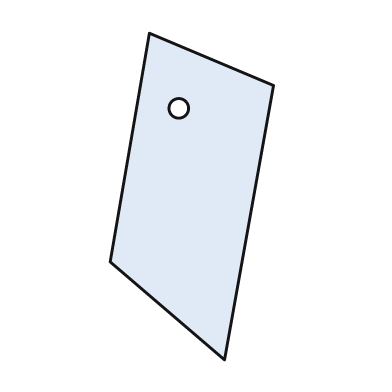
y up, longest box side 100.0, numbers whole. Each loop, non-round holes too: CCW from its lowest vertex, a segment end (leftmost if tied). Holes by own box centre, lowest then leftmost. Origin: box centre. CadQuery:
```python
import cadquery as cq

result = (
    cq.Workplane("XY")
    .moveTo(10.0, -50.0)
    .lineTo(25.0, 34.0)
    .lineTo(-13.0, 50.0)
    .lineTo(-25.0, -20.0)
    .close()
    .moveTo(-4.0, 27.0)
    .circle(3.0)
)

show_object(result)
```